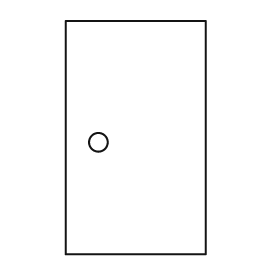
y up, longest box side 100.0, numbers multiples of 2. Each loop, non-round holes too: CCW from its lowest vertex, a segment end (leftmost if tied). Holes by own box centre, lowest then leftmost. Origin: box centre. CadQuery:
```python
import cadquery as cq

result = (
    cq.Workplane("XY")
    .moveTo(-30.0, -50.0)
    .lineTo(30.0, -50.0)
    .lineTo(30.0, 50.0)
    .lineTo(-30.0, 50.0)
    .close()
    .moveTo(-16.0, -2.0)
    .circle(4.0)
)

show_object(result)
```